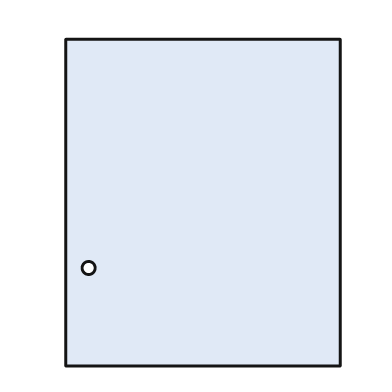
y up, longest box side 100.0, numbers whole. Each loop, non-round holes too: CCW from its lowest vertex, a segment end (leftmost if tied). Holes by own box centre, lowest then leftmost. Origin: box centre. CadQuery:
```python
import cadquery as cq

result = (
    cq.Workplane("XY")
    .moveTo(-42.0, -50.0)
    .lineTo(42.0, -50.0)
    .lineTo(42.0, 50.0)
    .lineTo(-42.0, 50.0)
    .close()
    .moveTo(-35.0, -20.0)
    .circle(2.0)
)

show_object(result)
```